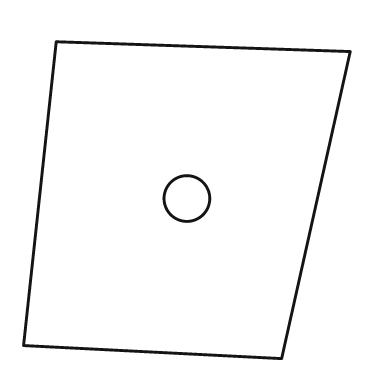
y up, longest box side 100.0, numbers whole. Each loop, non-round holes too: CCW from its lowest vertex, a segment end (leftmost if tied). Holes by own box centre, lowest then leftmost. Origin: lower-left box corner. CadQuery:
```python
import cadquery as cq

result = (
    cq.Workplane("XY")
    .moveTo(79.0, 0.0)
    .lineTo(100.0, 94.0)
    .lineTo(10.0, 97.0)
    .lineTo(0.0, 4.0)
    .close()
    .moveTo(50.0, 49.0)
    .circle(7.0)
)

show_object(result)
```